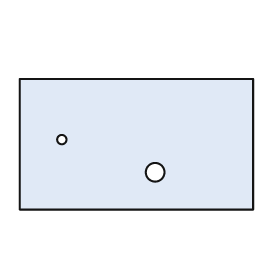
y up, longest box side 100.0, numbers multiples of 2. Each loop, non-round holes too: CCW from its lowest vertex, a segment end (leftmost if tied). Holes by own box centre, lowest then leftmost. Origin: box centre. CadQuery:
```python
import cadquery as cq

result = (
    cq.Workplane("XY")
    .moveTo(-50.0, -28.0)
    .lineTo(50.0, -28.0)
    .lineTo(50.0, 28.0)
    .lineTo(-50.0, 28.0)
    .close()
    .moveTo(8.0, -12.0)
    .circle(4.0)
    .moveTo(-32.0, 2.0)
    .circle(2.0)
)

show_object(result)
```